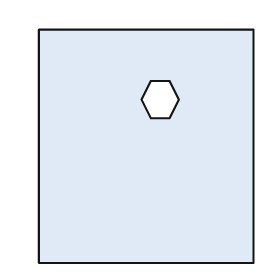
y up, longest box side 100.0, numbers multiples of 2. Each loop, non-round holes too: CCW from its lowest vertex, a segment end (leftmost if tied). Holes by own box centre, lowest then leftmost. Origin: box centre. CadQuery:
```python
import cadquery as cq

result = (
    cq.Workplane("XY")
    .moveTo(-46.0, -50.0)
    .lineTo(46.0, -50.0)
    .lineTo(46.0, 50.0)
    .lineTo(-46.0, 50.0)
    .close()
    .moveTo(2.0, 12.0)
    .lineTo(10.0, 12.0)
    .lineTo(14.0, 20.0)
    .lineTo(10.0, 28.0)
    .lineTo(2.0, 28.0)
    .lineTo(-2.0, 20.0)
    .close()
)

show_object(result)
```